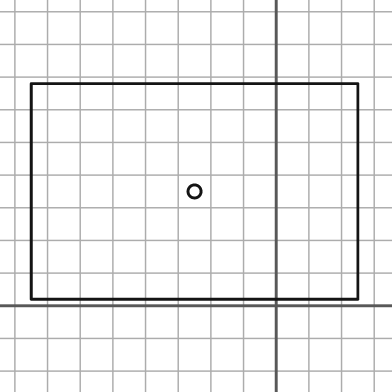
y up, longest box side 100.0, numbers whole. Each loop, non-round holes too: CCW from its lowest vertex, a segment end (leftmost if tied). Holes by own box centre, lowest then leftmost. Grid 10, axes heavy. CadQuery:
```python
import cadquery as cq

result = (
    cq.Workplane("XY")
    .moveTo(-75.0, 2.0)
    .lineTo(25.0, 2.0)
    .lineTo(25.0, 68.0)
    .lineTo(-75.0, 68.0)
    .close()
    .moveTo(-25.0, 35.0)
    .circle(2.0)
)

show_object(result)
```